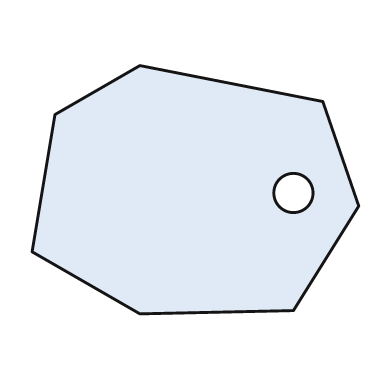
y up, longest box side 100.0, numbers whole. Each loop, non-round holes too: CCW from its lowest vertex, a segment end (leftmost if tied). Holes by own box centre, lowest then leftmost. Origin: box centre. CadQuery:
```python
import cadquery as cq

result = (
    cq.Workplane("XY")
    .moveTo(-17.0, -38.0)
    .lineTo(30.0, -37.0)
    .lineTo(50.0, -5.0)
    .lineTo(39.0, 27.0)
    .lineTo(-17.0, 38.0)
    .lineTo(-43.0, 23.0)
    .lineTo(-50.0, -19.0)
    .close()
    .moveTo(30.0, -1.0)
    .circle(6.0)
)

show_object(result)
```